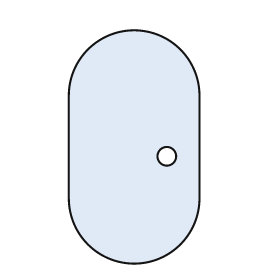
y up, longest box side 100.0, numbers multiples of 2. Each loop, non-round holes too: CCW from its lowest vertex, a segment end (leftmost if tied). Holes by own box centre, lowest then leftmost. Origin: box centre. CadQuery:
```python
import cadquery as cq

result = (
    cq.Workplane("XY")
    .moveTo(-28.0, -22.0)
    .threePointArc((0.0, -50.0), (28.0, -22.0))
    .lineTo(28.0, 22.0)
    .threePointArc((0.0, 50.0), (-28.0, 22.0))
    .close()
    .moveTo(14.0, -4.0)
    .circle(4.0)
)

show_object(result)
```